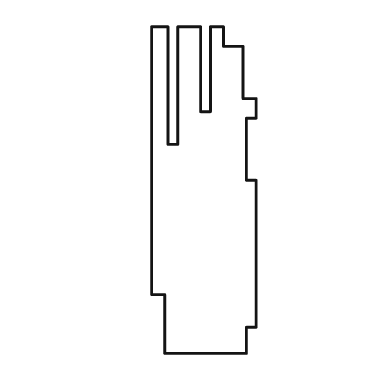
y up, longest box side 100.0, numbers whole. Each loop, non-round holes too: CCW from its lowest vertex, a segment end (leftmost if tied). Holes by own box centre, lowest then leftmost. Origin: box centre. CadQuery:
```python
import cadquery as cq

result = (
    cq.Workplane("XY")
    .moveTo(-12.0, -50.0)
    .lineTo(13.0, -50.0)
    .lineTo(13.0, -42.0)
    .lineTo(16.0, -42.0)
    .lineTo(16.0, 3.0)
    .lineTo(13.0, 3.0)
    .lineTo(13.0, 22.0)
    .lineTo(16.0, 22.0)
    .lineTo(16.0, 28.0)
    .lineTo(12.0, 28.0)
    .lineTo(12.0, 44.0)
    .lineTo(6.0, 44.0)
    .lineTo(6.0, 50.0)
    .lineTo(2.0, 50.0)
    .lineTo(2.0, 24.0)
    .lineTo(-1.0, 24.0)
    .lineTo(-1.0, 50.0)
    .lineTo(-8.0, 50.0)
    .lineTo(-8.0, 14.0)
    .lineTo(-11.0, 14.0)
    .lineTo(-11.0, 50.0)
    .lineTo(-16.0, 50.0)
    .lineTo(-16.0, -32.0)
    .lineTo(-12.0, -32.0)
    .close()
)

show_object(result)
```